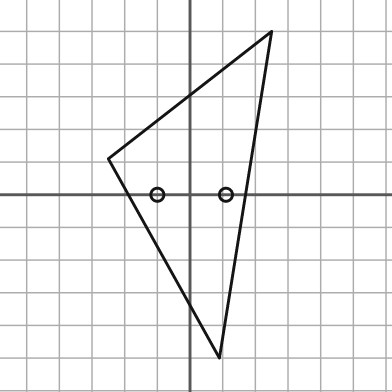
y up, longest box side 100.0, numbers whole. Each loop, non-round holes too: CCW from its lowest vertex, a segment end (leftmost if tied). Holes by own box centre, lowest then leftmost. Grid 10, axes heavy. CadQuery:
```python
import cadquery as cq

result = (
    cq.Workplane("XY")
    .moveTo(9.0, -50.0)
    .lineTo(25.0, 50.0)
    .lineTo(-25.0, 11.0)
    .close()
    .moveTo(-10.0, 0.0)
    .circle(2.0)
    .moveTo(11.0, 0.0)
    .circle(2.0)
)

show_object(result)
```